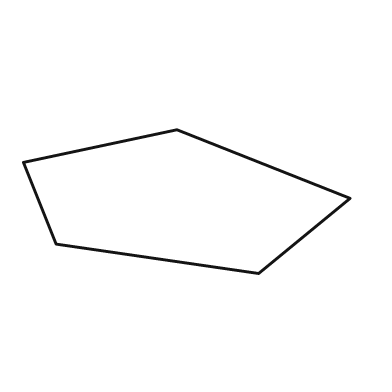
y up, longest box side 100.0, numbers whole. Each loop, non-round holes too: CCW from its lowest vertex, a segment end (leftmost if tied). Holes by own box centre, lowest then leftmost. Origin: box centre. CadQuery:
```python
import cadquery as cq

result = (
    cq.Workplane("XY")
    .moveTo(22.0, -22.0)
    .lineTo(50.0, 1.0)
    .lineTo(-3.0, 22.0)
    .lineTo(-50.0, 12.0)
    .lineTo(-40.0, -13.0)
    .close()
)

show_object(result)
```